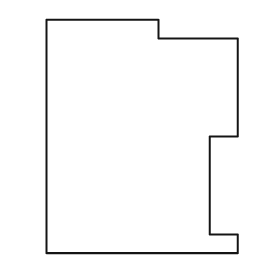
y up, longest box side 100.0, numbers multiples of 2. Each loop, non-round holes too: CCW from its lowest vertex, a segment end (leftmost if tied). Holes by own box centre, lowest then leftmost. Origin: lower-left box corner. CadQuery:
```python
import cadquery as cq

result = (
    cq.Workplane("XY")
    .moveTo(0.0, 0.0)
    .lineTo(82.0, 0.0)
    .lineTo(82.0, 8.0)
    .lineTo(70.0, 8.0)
    .lineTo(70.0, 50.0)
    .lineTo(82.0, 50.0)
    .lineTo(82.0, 92.0)
    .lineTo(48.0, 92.0)
    .lineTo(48.0, 100.0)
    .lineTo(0.0, 100.0)
    .close()
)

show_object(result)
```